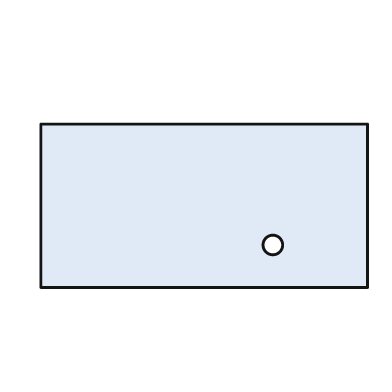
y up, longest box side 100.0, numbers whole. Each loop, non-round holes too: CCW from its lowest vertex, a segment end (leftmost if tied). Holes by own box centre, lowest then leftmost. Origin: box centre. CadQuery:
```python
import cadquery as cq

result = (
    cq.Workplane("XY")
    .moveTo(-50.0, -25.0)
    .lineTo(50.0, -25.0)
    .lineTo(50.0, 25.0)
    .lineTo(-50.0, 25.0)
    .close()
    .moveTo(21.0, -12.0)
    .circle(3.0)
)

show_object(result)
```